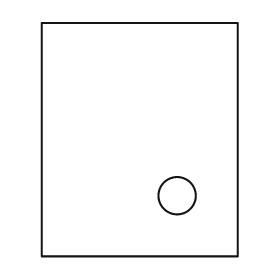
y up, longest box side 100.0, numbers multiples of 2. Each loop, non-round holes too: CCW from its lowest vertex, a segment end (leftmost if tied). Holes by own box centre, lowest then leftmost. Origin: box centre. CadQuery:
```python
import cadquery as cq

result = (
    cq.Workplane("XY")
    .moveTo(-42.0, -50.0)
    .lineTo(42.0, -50.0)
    .lineTo(42.0, 50.0)
    .lineTo(-42.0, 50.0)
    .close()
    .moveTo(16.0, -24.0)
    .circle(8.0)
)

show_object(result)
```